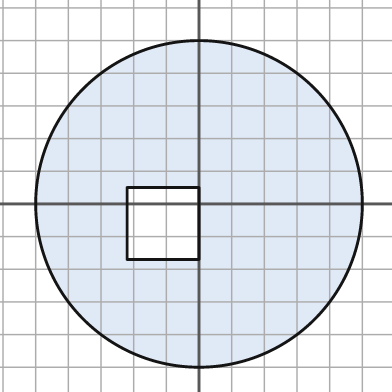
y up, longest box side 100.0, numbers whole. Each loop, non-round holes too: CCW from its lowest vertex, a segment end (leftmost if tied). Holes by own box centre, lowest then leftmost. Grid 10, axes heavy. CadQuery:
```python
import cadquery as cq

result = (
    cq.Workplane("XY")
    .moveTo(0.0, 0.0)
    .circle(50.0)
    .moveTo(-22.0, -17.0)
    .lineTo(0.0, -17.0)
    .lineTo(0.0, 5.0)
    .lineTo(-22.0, 5.0)
    .close()
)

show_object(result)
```